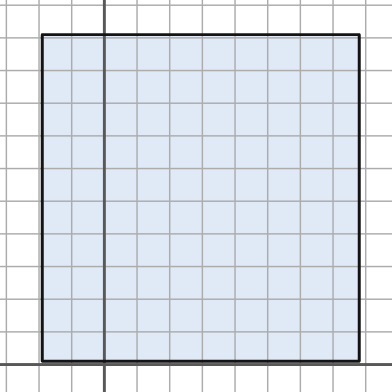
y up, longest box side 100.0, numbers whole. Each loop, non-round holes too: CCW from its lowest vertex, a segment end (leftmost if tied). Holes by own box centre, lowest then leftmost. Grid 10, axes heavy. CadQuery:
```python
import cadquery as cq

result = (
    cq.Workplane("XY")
    .moveTo(-19.0, 1.0)
    .lineTo(78.0, 1.0)
    .lineTo(78.0, 101.0)
    .lineTo(-19.0, 101.0)
    .close()
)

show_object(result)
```